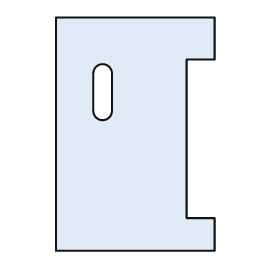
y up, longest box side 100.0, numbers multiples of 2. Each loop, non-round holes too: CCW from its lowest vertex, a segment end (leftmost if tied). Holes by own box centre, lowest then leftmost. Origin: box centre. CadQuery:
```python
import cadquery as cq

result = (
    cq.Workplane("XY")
    .moveTo(-34.0, -50.0)
    .lineTo(34.0, -50.0)
    .lineTo(34.0, -36.0)
    .lineTo(22.0, -36.0)
    .lineTo(22.0, 32.0)
    .lineTo(34.0, 32.0)
    .lineTo(34.0, 50.0)
    .lineTo(-34.0, 50.0)
    .close()
    .moveTo(-18.0, 10.0)
    .threePointArc((-14.0, 6.0), (-10.0, 10.0))
    .lineTo(-10.0, 26.0)
    .threePointArc((-14.0, 30.0), (-18.0, 26.0))
    .close()
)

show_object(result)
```